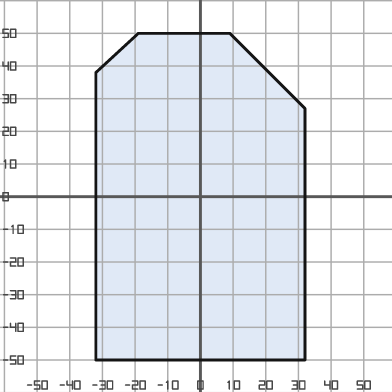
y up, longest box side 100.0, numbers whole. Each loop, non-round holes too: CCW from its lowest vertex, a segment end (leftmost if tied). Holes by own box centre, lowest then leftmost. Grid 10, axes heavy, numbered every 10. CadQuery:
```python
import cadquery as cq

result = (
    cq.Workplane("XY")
    .moveTo(-32.0, -50.0)
    .lineTo(32.0, -50.0)
    .lineTo(32.0, 27.0)
    .lineTo(9.0, 50.0)
    .lineTo(-19.0, 50.0)
    .lineTo(-32.0, 38.0)
    .close()
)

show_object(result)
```